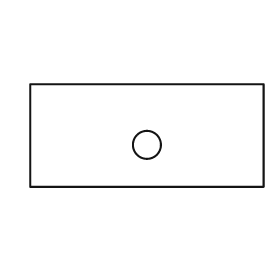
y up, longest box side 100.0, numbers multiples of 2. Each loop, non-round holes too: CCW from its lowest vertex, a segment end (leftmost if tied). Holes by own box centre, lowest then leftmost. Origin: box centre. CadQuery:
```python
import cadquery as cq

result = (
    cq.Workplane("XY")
    .moveTo(-50.0, -22.0)
    .lineTo(50.0, -22.0)
    .lineTo(50.0, 22.0)
    .lineTo(-50.0, 22.0)
    .close()
    .moveTo(0.0, -4.0)
    .circle(6.0)
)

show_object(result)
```